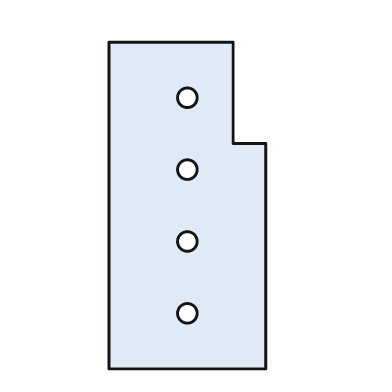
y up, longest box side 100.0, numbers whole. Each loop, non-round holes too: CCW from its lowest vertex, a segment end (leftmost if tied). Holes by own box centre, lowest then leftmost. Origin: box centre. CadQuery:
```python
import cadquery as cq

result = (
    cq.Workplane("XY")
    .moveTo(-24.0, -50.0)
    .lineTo(24.0, -50.0)
    .lineTo(24.0, 19.0)
    .lineTo(14.0, 19.0)
    .lineTo(14.0, 50.0)
    .lineTo(-24.0, 50.0)
    .close()
    .moveTo(0.0, -33.0)
    .circle(3.0)
    .moveTo(0.0, -11.0)
    .circle(3.0)
    .moveTo(0.0, 11.0)
    .circle(3.0)
    .moveTo(0.0, 33.0)
    .circle(3.0)
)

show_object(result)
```